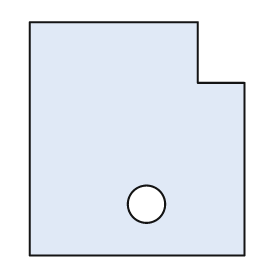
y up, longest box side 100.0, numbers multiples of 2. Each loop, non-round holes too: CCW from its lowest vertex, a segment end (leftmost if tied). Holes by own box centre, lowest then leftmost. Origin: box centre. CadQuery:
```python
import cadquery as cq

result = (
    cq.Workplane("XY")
    .moveTo(-46.0, -50.0)
    .lineTo(46.0, -50.0)
    .lineTo(46.0, 24.0)
    .lineTo(26.0, 24.0)
    .lineTo(26.0, 50.0)
    .lineTo(-46.0, 50.0)
    .close()
    .moveTo(4.0, -28.0)
    .circle(8.0)
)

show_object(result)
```